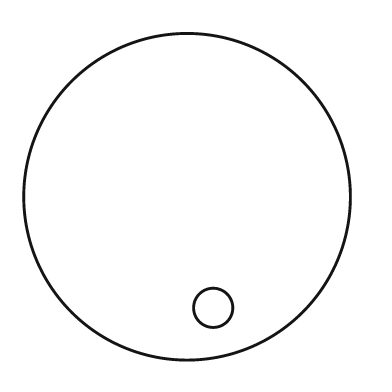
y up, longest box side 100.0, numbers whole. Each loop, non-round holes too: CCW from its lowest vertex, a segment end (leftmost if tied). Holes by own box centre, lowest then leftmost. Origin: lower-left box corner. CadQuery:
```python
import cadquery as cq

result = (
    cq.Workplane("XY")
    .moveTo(50.0, 50.0)
    .circle(50.0)
    .moveTo(58.0, 16.0)
    .circle(6.0)
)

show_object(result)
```